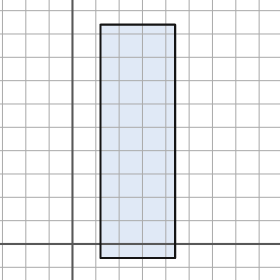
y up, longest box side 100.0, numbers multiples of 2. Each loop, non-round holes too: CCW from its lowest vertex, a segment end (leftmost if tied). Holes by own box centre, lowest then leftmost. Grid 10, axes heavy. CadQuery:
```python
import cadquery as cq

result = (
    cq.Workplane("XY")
    .moveTo(12.0, -6.0)
    .lineTo(44.0, -6.0)
    .lineTo(44.0, 94.0)
    .lineTo(12.0, 94.0)
    .close()
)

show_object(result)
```